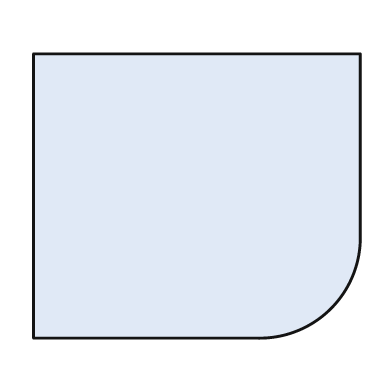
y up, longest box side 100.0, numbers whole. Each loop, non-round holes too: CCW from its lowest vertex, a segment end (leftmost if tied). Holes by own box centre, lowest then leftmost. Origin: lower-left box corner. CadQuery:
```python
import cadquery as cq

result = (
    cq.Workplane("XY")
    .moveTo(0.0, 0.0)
    .lineTo(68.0, 0.0)
    .threePointArc((91.0, 9.0), (100.0, 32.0))
    .lineTo(100.0, 87.0)
    .lineTo(0.0, 87.0)
    .close()
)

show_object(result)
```